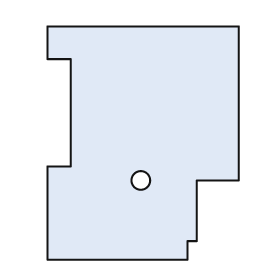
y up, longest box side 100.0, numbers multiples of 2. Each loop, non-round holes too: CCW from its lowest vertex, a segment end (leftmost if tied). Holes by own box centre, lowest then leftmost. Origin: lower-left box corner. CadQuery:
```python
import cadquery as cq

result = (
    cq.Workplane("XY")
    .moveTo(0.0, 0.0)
    .lineTo(60.0, 0.0)
    .lineTo(60.0, 8.0)
    .lineTo(64.0, 8.0)
    .lineTo(64.0, 34.0)
    .lineTo(82.0, 34.0)
    .lineTo(82.0, 100.0)
    .lineTo(0.0, 100.0)
    .lineTo(0.0, 86.0)
    .lineTo(10.0, 86.0)
    .lineTo(10.0, 40.0)
    .lineTo(0.0, 40.0)
    .close()
    .moveTo(40.0, 34.0)
    .circle(4.0)
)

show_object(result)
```